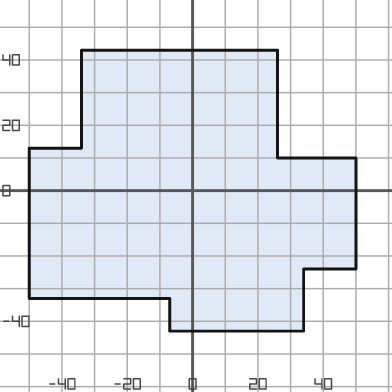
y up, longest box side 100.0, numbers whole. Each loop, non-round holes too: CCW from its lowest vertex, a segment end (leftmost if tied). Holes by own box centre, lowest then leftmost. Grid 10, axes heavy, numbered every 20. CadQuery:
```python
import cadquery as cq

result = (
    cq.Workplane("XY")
    .moveTo(-7.0, -43.0)
    .lineTo(34.0, -43.0)
    .lineTo(34.0, -24.0)
    .lineTo(50.0, -24.0)
    .lineTo(50.0, 10.0)
    .lineTo(26.0, 10.0)
    .lineTo(26.0, 43.0)
    .lineTo(-34.0, 43.0)
    .lineTo(-34.0, 13.0)
    .lineTo(-50.0, 13.0)
    .lineTo(-50.0, -33.0)
    .lineTo(-7.0, -33.0)
    .close()
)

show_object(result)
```